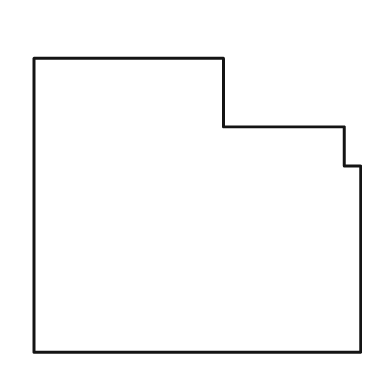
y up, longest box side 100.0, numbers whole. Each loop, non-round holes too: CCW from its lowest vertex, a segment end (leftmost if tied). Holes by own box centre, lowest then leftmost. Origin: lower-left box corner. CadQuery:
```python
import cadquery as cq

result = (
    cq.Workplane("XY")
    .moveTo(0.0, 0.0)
    .lineTo(100.0, 0.0)
    .lineTo(100.0, 57.0)
    .lineTo(95.0, 57.0)
    .lineTo(95.0, 69.0)
    .lineTo(58.0, 69.0)
    .lineTo(58.0, 90.0)
    .lineTo(0.0, 90.0)
    .close()
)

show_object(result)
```